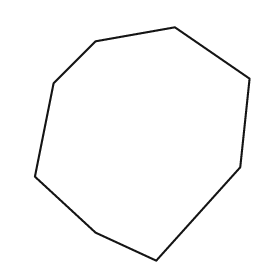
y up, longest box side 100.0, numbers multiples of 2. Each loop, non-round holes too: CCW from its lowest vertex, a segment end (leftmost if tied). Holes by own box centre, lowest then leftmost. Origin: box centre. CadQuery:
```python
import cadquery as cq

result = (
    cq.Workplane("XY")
    .moveTo(6.0, -50.0)
    .lineTo(42.0, -10.0)
    .lineTo(46.0, 28.0)
    .lineTo(14.0, 50.0)
    .lineTo(-20.0, 44.0)
    .lineTo(-38.0, 26.0)
    .lineTo(-46.0, -14.0)
    .lineTo(-20.0, -38.0)
    .close()
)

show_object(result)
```